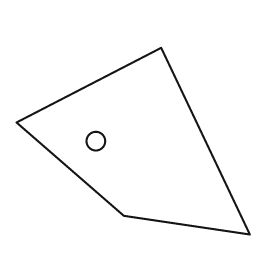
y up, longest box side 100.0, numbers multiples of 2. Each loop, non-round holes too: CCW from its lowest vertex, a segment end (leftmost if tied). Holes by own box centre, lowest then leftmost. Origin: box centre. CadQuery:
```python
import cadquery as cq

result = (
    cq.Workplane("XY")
    .moveTo(50.0, -40.0)
    .lineTo(12.0, 40.0)
    .lineTo(-50.0, 8.0)
    .lineTo(-4.0, -32.0)
    .close()
    .moveTo(-16.0, 0.0)
    .circle(4.0)
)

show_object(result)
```